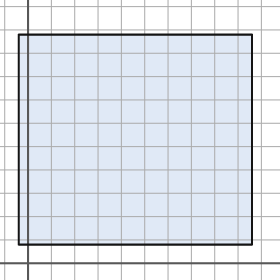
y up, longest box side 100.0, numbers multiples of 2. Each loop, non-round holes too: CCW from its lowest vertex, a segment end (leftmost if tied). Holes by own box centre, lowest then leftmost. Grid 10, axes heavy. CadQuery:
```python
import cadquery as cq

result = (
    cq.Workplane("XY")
    .moveTo(-4.0, 8.0)
    .lineTo(96.0, 8.0)
    .lineTo(96.0, 98.0)
    .lineTo(-4.0, 98.0)
    .close()
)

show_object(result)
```